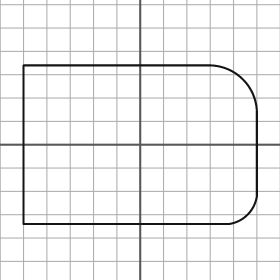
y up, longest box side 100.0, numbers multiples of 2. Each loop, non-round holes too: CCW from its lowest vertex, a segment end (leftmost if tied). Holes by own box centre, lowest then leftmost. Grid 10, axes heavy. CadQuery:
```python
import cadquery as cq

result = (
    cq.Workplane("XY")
    .moveTo(-50.0, -34.0)
    .lineTo(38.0, -34.0)
    .threePointArc((46.0, -30.0), (50.0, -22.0))
    .lineTo(50.0, 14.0)
    .threePointArc((44.0, 28.0), (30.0, 34.0))
    .lineTo(-50.0, 34.0)
    .close()
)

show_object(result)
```